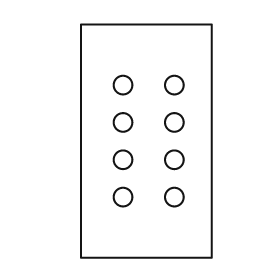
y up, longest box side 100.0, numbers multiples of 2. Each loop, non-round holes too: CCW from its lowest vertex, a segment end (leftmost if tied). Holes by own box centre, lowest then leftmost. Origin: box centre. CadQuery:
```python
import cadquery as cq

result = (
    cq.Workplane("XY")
    .moveTo(-28.0, -50.0)
    .lineTo(28.0, -50.0)
    .lineTo(28.0, 50.0)
    .lineTo(-28.0, 50.0)
    .close()
    .moveTo(-10.0, -24.0)
    .circle(4.0)
    .moveTo(12.0, -24.0)
    .circle(4.0)
    .moveTo(-10.0, -8.0)
    .circle(4.0)
    .moveTo(12.0, -8.0)
    .circle(4.0)
    .moveTo(-10.0, 8.0)
    .circle(4.0)
    .moveTo(12.0, 8.0)
    .circle(4.0)
    .moveTo(-10.0, 24.0)
    .circle(4.0)
    .moveTo(12.0, 24.0)
    .circle(4.0)
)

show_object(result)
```